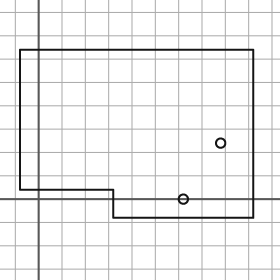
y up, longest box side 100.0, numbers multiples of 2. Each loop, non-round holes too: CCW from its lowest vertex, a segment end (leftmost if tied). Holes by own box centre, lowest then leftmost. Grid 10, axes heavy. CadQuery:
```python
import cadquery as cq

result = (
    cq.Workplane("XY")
    .moveTo(32.0, -8.0)
    .lineTo(92.0, -8.0)
    .lineTo(92.0, 64.0)
    .lineTo(-8.0, 64.0)
    .lineTo(-8.0, 4.0)
    .lineTo(32.0, 4.0)
    .close()
    .moveTo(62.0, 0.0)
    .circle(2.0)
    .moveTo(78.0, 24.0)
    .circle(2.0)
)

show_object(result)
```